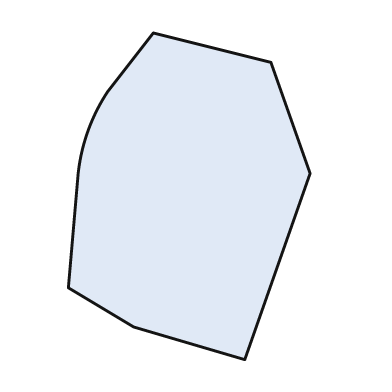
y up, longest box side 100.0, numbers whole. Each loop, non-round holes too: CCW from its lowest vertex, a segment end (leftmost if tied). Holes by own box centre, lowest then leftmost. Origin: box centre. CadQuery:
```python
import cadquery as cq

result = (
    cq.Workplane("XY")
    .moveTo(17.0, -50.0)
    .lineTo(37.0, 7.0)
    .lineTo(25.0, 41.0)
    .lineTo(-11.0, 50.0)
    .lineTo(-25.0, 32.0)
    .threePointArc((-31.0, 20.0), (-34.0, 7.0))
    .lineTo(-37.0, -28.0)
    .lineTo(-17.0, -40.0)
    .close()
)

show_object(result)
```